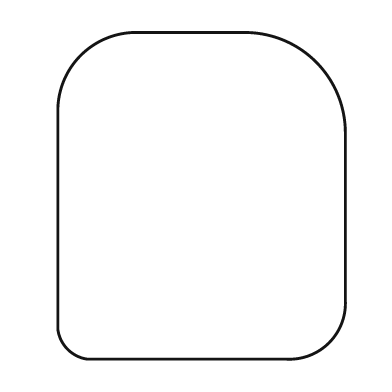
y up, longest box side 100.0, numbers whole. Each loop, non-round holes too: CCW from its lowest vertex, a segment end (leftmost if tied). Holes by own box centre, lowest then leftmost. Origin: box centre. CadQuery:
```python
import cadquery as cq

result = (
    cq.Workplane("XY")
    .moveTo(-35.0, -50.0)
    .lineTo(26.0, -50.0)
    .threePointArc((39.0, -45.0), (44.0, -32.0))
    .lineTo(44.0, 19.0)
    .threePointArc((35.0, 41.0), (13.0, 50.0))
    .lineTo(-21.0, 50.0)
    .threePointArc((-37.0, 43.0), (-44.0, 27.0))
    .lineTo(-44.0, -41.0)
    .threePointArc((-41.0, -47.0), (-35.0, -50.0))
    .close()
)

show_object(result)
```